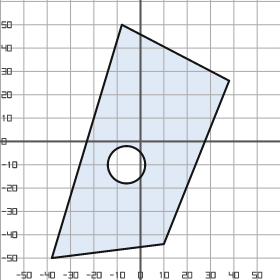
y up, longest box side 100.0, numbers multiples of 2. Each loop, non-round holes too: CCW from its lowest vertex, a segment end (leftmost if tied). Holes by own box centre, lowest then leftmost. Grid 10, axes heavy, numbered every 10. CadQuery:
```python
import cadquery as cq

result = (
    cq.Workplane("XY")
    .moveTo(-38.0, -50.0)
    .lineTo(10.0, -44.0)
    .lineTo(38.0, 26.0)
    .lineTo(-8.0, 50.0)
    .close()
    .moveTo(-6.0, -10.0)
    .circle(8.0)
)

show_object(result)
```